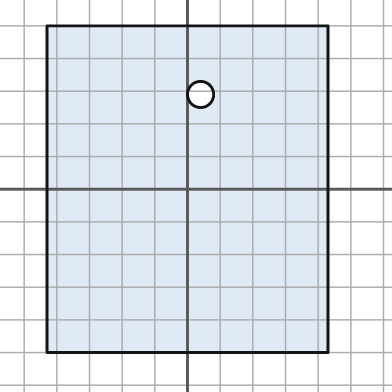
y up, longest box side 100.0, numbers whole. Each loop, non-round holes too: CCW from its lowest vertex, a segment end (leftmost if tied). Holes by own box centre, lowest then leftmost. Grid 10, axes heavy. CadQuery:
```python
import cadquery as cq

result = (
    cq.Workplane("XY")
    .moveTo(-43.0, -50.0)
    .lineTo(43.0, -50.0)
    .lineTo(43.0, 50.0)
    .lineTo(-43.0, 50.0)
    .close()
    .moveTo(4.0, 29.0)
    .circle(4.0)
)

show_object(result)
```